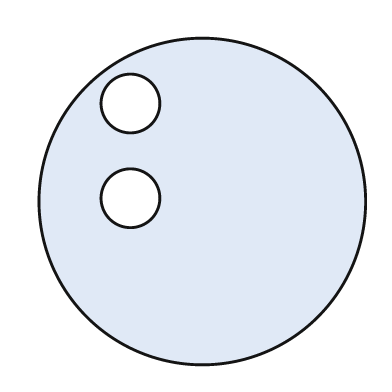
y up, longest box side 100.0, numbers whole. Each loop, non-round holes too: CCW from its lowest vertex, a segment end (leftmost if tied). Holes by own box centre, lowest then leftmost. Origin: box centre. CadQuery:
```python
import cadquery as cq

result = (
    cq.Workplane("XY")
    .moveTo(0.0, 0.0)
    .circle(50.0)
    .moveTo(-22.0, 1.0)
    .circle(9.0)
    .moveTo(-22.0, 30.0)
    .circle(9.0)
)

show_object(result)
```